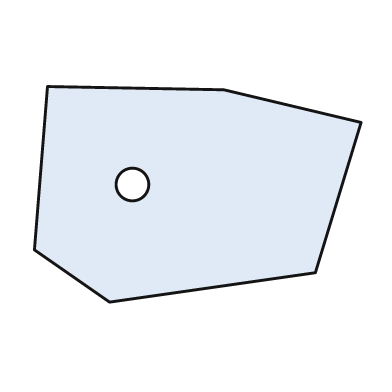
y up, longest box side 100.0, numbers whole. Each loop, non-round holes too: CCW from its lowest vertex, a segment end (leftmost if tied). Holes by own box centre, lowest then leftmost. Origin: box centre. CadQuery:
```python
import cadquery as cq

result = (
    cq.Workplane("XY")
    .moveTo(-27.0, -33.0)
    .lineTo(36.0, -24.0)
    .lineTo(50.0, 22.0)
    .lineTo(8.0, 32.0)
    .lineTo(-46.0, 33.0)
    .lineTo(-50.0, -17.0)
    .close()
    .moveTo(-20.0, 3.0)
    .circle(5.0)
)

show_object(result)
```